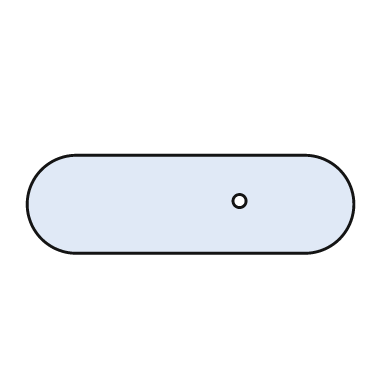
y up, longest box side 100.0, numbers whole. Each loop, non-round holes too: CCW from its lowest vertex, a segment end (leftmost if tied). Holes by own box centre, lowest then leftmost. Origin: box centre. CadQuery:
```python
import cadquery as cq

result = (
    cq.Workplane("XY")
    .moveTo(-35.0, -15.0)
    .lineTo(35.0, -15.0)
    .threePointArc((50.0, 0.0), (35.0, 15.0))
    .lineTo(-35.0, 15.0)
    .threePointArc((-50.0, 0.0), (-35.0, -15.0))
    .close()
    .moveTo(15.0, 1.0)
    .circle(2.0)
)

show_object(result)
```